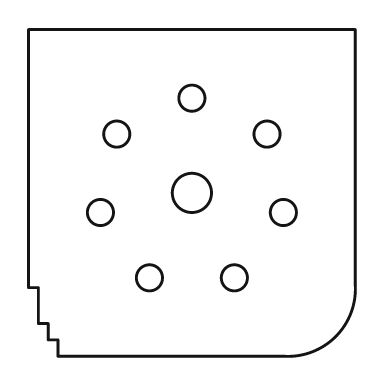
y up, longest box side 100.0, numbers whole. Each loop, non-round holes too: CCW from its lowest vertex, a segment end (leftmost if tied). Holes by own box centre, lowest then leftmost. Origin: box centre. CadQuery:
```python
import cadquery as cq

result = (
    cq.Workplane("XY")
    .moveTo(-41.0, -50.0)
    .lineTo(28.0, -50.0)
    .threePointArc((44.0, -44.0), (50.0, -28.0))
    .lineTo(50.0, 50.0)
    .lineTo(-50.0, 50.0)
    .lineTo(-50.0, -29.0)
    .lineTo(-47.0, -29.0)
    .lineTo(-47.0, -40.0)
    .lineTo(-44.0, -40.0)
    .lineTo(-44.0, -45.0)
    .lineTo(-41.0, -45.0)
    .close()
    .moveTo(-13.0, -26.0)
    .circle(4.0)
    .moveTo(13.0, -26.0)
    .circle(4.0)
    .moveTo(-28.0, -6.0)
    .circle(4.0)
    .moveTo(28.0, -6.0)
    .circle(4.0)
    .moveTo(0.0, 0.0)
    .circle(6.0)
    .moveTo(-23.0, 18.0)
    .circle(4.0)
    .moveTo(23.0, 18.0)
    .circle(4.0)
    .moveTo(0.0, 29.0)
    .circle(4.0)
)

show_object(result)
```